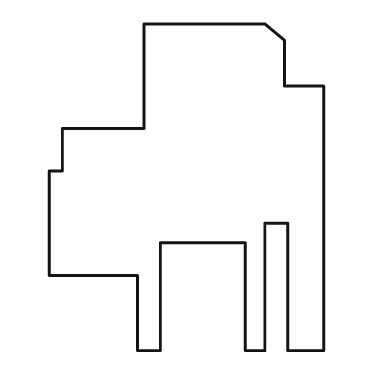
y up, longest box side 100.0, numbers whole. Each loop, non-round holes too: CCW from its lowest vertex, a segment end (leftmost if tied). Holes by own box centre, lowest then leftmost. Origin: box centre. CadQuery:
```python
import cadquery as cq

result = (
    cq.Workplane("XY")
    .moveTo(-15.0, -50.0)
    .lineTo(-8.0, -50.0)
    .lineTo(-8.0, -17.0)
    .lineTo(18.0, -17.0)
    .lineTo(18.0, -50.0)
    .lineTo(24.0, -50.0)
    .lineTo(24.0, -11.0)
    .lineTo(31.0, -11.0)
    .lineTo(31.0, -50.0)
    .lineTo(42.0, -50.0)
    .lineTo(42.0, 31.0)
    .lineTo(30.0, 31.0)
    .lineTo(30.0, 45.0)
    .lineTo(24.0, 50.0)
    .lineTo(-13.0, 50.0)
    .lineTo(-13.0, 18.0)
    .lineTo(-38.0, 18.0)
    .lineTo(-38.0, 5.0)
    .lineTo(-42.0, 5.0)
    .lineTo(-42.0, -27.0)
    .lineTo(-15.0, -27.0)
    .close()
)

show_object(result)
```